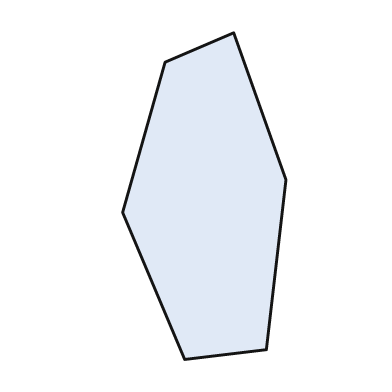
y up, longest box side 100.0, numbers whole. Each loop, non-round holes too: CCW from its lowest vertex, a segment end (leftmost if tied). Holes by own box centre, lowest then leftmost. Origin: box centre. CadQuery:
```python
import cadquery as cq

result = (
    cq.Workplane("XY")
    .moveTo(-6.0, -50.0)
    .lineTo(19.0, -47.0)
    .lineTo(25.0, 5.0)
    .lineTo(9.0, 50.0)
    .lineTo(-12.0, 41.0)
    .lineTo(-25.0, -5.0)
    .close()
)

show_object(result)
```